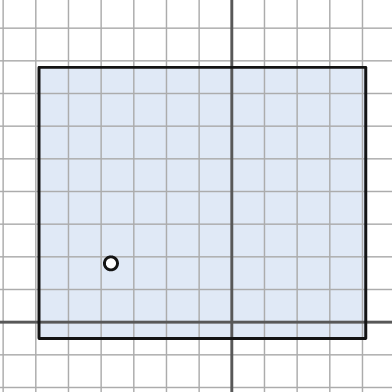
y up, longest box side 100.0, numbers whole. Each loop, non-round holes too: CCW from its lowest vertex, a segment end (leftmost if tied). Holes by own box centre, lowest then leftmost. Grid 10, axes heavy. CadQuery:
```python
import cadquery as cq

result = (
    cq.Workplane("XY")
    .moveTo(-59.0, -5.0)
    .lineTo(41.0, -5.0)
    .lineTo(41.0, 78.0)
    .lineTo(-59.0, 78.0)
    .close()
    .moveTo(-37.0, 18.0)
    .circle(2.0)
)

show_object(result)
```